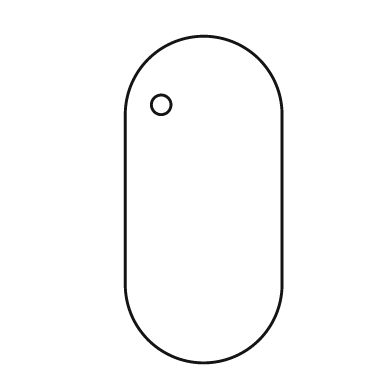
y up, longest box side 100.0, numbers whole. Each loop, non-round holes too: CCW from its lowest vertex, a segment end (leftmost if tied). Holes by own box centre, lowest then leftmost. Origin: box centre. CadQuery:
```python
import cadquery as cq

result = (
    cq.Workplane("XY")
    .moveTo(-24.0, -26.0)
    .threePointArc((0.0, -50.0), (24.0, -26.0))
    .lineTo(24.0, 26.0)
    .threePointArc((0.0, 50.0), (-24.0, 26.0))
    .close()
    .moveTo(-13.0, 29.0)
    .circle(3.0)
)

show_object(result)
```